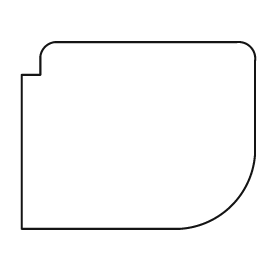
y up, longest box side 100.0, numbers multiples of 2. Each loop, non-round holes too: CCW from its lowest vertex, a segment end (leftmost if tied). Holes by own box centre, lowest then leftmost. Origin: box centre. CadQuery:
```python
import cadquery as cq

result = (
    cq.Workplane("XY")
    .moveTo(-50.0, -40.0)
    .lineTo(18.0, -40.0)
    .threePointArc((40.0, -30.0), (50.0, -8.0))
    .lineTo(50.0, 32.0)
    .threePointArc((48.0, 38.0), (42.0, 40.0))
    .lineTo(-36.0, 40.0)
    .threePointArc((-40.0, 38.0), (-42.0, 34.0))
    .lineTo(-42.0, 26.0)
    .lineTo(-50.0, 26.0)
    .close()
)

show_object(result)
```